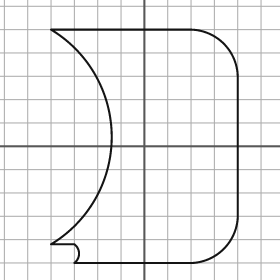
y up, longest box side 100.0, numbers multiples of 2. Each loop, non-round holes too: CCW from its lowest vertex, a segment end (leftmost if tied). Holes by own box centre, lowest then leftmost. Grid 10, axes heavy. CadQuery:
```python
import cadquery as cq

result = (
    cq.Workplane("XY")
    .moveTo(-30.0, -50.0)
    .lineTo(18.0, -50.0)
    .threePointArc((34.0, -44.0), (40.0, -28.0))
    .lineTo(40.0, 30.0)
    .threePointArc((34.0, 44.0), (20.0, 50.0))
    .lineTo(-40.0, 50.0)
    .threePointArc((-14.0, 4.0), (-40.0, -42.0))
    .lineTo(-30.0, -42.0)
    .threePointArc((-28.0, -46.0), (-30.0, -50.0))
    .close()
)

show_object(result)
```